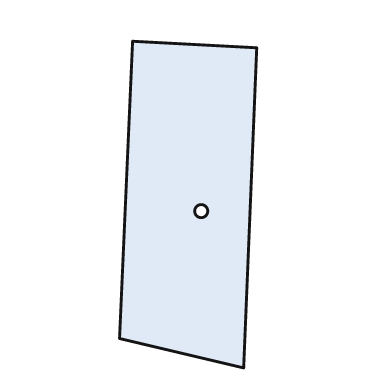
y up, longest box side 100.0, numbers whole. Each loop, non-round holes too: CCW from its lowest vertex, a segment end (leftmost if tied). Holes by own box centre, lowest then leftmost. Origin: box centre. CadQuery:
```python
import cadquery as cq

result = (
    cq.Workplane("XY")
    .moveTo(17.0, -50.0)
    .lineTo(21.0, 48.0)
    .lineTo(-17.0, 50.0)
    .lineTo(-21.0, -41.0)
    .close()
    .moveTo(4.0, -2.0)
    .circle(2.0)
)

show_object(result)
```